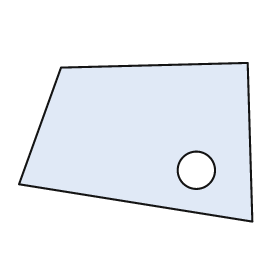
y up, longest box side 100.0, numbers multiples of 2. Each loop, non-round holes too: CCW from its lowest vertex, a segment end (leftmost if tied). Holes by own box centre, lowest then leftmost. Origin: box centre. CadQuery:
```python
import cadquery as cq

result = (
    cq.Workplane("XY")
    .moveTo(50.0, -34.0)
    .lineTo(48.0, 34.0)
    .lineTo(-32.0, 32.0)
    .lineTo(-50.0, -18.0)
    .close()
    .moveTo(26.0, -12.0)
    .circle(8.0)
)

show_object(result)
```